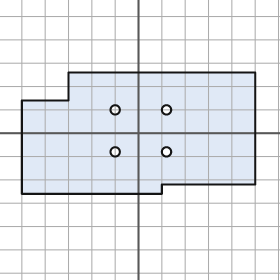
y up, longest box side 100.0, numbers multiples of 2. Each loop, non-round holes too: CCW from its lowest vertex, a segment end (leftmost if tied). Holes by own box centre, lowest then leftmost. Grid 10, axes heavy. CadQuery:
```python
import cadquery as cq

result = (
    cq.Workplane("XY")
    .moveTo(-50.0, -26.0)
    .lineTo(10.0, -26.0)
    .lineTo(10.0, -22.0)
    .lineTo(50.0, -22.0)
    .lineTo(50.0, 26.0)
    .lineTo(-30.0, 26.0)
    .lineTo(-30.0, 14.0)
    .lineTo(-50.0, 14.0)
    .close()
    .moveTo(-10.0, -8.0)
    .circle(2.0)
    .moveTo(12.0, -8.0)
    .circle(2.0)
    .moveTo(-10.0, 10.0)
    .circle(2.0)
    .moveTo(12.0, 10.0)
    .circle(2.0)
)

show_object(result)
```